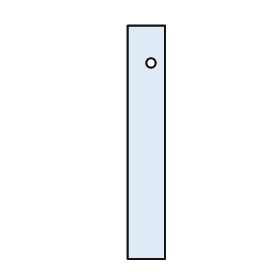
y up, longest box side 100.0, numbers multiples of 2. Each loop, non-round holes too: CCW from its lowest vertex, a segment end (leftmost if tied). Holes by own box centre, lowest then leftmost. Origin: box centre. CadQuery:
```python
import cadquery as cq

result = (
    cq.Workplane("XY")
    .moveTo(-8.0, -50.0)
    .lineTo(8.0, -50.0)
    .lineTo(8.0, 50.0)
    .lineTo(-8.0, 50.0)
    .close()
    .moveTo(2.0, 34.0)
    .circle(2.0)
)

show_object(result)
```